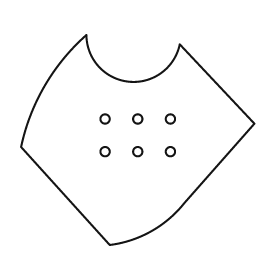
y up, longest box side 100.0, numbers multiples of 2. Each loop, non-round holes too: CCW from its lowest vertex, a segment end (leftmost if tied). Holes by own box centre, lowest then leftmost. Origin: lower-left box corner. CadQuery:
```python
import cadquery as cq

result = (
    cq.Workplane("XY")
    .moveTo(38.0, 0.0)
    .threePointArc((56.0, 6.0), (70.0, 18.0))
    .lineTo(100.0, 52.0)
    .lineTo(68.0, 86.0)
    .threePointArc((46.0, 70.0), (28.0, 90.0))
    .threePointArc((10.0, 68.0), (0.0, 42.0))
    .close()
    .moveTo(36.0, 40.0)
    .circle(2.0)
    .moveTo(50.0, 40.0)
    .circle(2.0)
    .moveTo(64.0, 40.0)
    .circle(2.0)
    .moveTo(36.0, 54.0)
    .circle(2.0)
    .moveTo(50.0, 54.0)
    .circle(2.0)
    .moveTo(64.0, 54.0)
    .circle(2.0)
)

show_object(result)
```